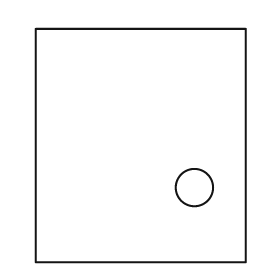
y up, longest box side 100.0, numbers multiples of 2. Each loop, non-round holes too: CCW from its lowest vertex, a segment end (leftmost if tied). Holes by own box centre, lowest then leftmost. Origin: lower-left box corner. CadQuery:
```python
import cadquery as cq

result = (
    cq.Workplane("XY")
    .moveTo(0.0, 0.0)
    .lineTo(90.0, 0.0)
    .lineTo(90.0, 100.0)
    .lineTo(0.0, 100.0)
    .close()
    .moveTo(68.0, 32.0)
    .circle(8.0)
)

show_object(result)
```